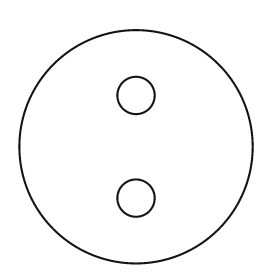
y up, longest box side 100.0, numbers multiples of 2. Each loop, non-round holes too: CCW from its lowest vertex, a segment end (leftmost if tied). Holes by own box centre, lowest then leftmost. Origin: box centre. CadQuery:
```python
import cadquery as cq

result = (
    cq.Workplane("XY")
    .moveTo(0.0, 0.0)
    .circle(50.0)
    .moveTo(0.0, -22.0)
    .circle(8.0)
    .moveTo(0.0, 22.0)
    .circle(8.0)
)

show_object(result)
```